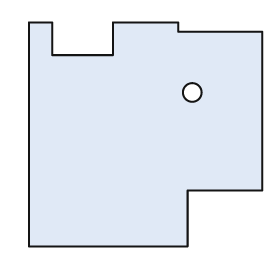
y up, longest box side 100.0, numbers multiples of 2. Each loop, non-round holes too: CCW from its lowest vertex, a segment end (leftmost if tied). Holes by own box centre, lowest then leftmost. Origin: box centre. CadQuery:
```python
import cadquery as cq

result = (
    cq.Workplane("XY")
    .moveTo(-50.0, -48.0)
    .lineTo(18.0, -48.0)
    .lineTo(18.0, -24.0)
    .lineTo(50.0, -24.0)
    .lineTo(50.0, 44.0)
    .lineTo(14.0, 44.0)
    .lineTo(14.0, 48.0)
    .lineTo(-14.0, 48.0)
    .lineTo(-14.0, 34.0)
    .lineTo(-40.0, 34.0)
    .lineTo(-40.0, 48.0)
    .lineTo(-50.0, 48.0)
    .close()
    .moveTo(20.0, 18.0)
    .circle(4.0)
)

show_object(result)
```